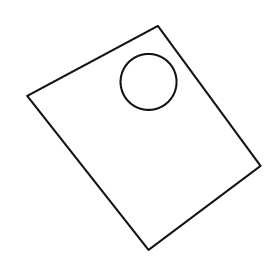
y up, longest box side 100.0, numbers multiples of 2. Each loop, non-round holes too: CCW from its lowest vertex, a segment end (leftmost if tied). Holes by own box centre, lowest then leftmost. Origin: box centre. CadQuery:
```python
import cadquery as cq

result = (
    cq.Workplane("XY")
    .moveTo(2.0, -48.0)
    .lineTo(50.0, -12.0)
    .lineTo(6.0, 48.0)
    .lineTo(-50.0, 18.0)
    .close()
    .moveTo(2.0, 24.0)
    .circle(12.0)
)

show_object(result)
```